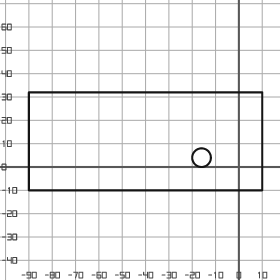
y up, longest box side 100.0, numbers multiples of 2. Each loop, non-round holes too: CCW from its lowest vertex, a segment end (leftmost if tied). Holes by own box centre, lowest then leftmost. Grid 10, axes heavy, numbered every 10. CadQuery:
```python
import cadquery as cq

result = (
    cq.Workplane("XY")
    .moveTo(-90.0, -10.0)
    .lineTo(10.0, -10.0)
    .lineTo(10.0, 32.0)
    .lineTo(-90.0, 32.0)
    .close()
    .moveTo(-16.0, 4.0)
    .circle(4.0)
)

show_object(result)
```